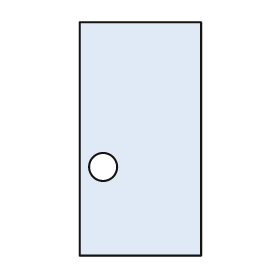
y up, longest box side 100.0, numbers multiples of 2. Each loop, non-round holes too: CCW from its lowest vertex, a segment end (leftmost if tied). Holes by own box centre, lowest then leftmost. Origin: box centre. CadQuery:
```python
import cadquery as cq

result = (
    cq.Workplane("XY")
    .moveTo(-26.0, -50.0)
    .lineTo(26.0, -50.0)
    .lineTo(26.0, 50.0)
    .lineTo(-26.0, 50.0)
    .close()
    .moveTo(-16.0, -12.0)
    .circle(6.0)
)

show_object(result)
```